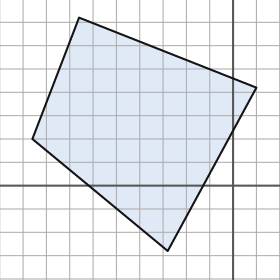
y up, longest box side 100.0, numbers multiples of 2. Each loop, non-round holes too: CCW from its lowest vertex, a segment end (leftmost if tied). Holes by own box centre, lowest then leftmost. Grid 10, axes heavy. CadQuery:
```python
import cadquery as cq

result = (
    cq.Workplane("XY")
    .moveTo(-28.0, -28.0)
    .lineTo(10.0, 42.0)
    .lineTo(-66.0, 72.0)
    .lineTo(-86.0, 20.0)
    .close()
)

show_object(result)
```